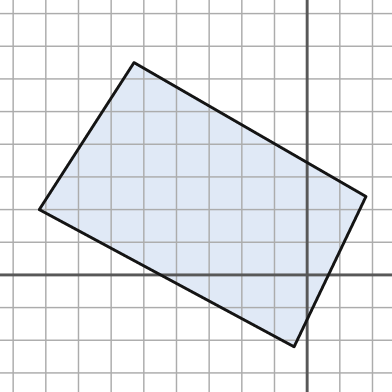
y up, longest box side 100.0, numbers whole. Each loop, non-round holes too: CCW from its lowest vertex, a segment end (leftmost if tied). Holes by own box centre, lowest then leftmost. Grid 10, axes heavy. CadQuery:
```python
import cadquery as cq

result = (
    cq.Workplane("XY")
    .moveTo(-4.0, -22.0)
    .lineTo(18.0, 24.0)
    .lineTo(-53.0, 65.0)
    .lineTo(-82.0, 20.0)
    .close()
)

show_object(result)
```